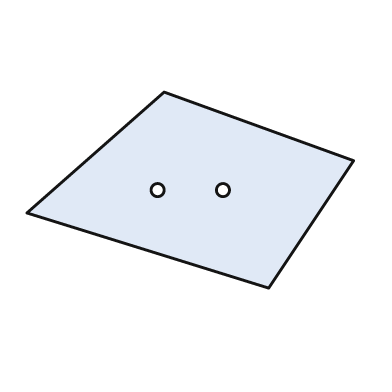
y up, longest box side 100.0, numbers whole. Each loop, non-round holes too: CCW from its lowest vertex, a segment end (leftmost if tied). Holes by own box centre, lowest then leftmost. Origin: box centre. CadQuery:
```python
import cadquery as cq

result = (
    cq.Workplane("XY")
    .moveTo(24.0, -30.0)
    .lineTo(50.0, 9.0)
    .lineTo(-8.0, 30.0)
    .lineTo(-50.0, -7.0)
    .close()
    .moveTo(-10.0, 0.0)
    .circle(2.0)
    .moveTo(10.0, 0.0)
    .circle(2.0)
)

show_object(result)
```